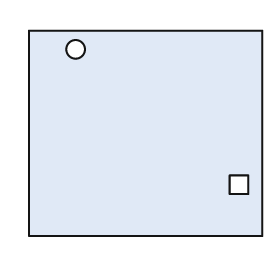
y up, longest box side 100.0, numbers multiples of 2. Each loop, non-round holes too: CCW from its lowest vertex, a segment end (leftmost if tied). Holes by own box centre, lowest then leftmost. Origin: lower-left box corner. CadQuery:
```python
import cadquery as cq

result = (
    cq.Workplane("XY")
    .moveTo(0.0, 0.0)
    .lineTo(100.0, 0.0)
    .lineTo(100.0, 88.0)
    .lineTo(0.0, 88.0)
    .close()
    .moveTo(86.0, 18.0)
    .lineTo(94.0, 18.0)
    .lineTo(94.0, 26.0)
    .lineTo(86.0, 26.0)
    .close()
    .moveTo(20.0, 80.0)
    .circle(4.0)
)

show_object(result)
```